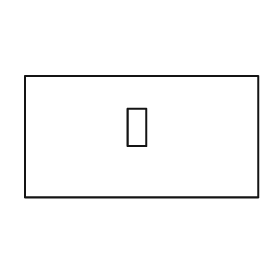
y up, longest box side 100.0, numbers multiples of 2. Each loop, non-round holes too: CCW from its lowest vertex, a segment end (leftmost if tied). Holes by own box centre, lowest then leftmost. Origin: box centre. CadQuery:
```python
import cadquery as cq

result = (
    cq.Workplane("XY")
    .moveTo(-50.0, -26.0)
    .lineTo(50.0, -26.0)
    .lineTo(50.0, 26.0)
    .lineTo(-50.0, 26.0)
    .close()
    .moveTo(-6.0, -4.0)
    .lineTo(2.0, -4.0)
    .lineTo(2.0, 12.0)
    .lineTo(-6.0, 12.0)
    .close()
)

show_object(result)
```